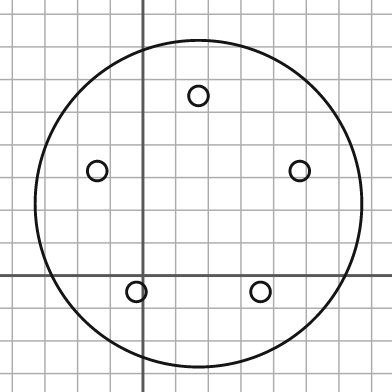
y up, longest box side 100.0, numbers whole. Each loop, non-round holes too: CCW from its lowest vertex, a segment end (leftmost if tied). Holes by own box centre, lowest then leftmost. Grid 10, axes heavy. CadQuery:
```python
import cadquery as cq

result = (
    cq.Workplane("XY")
    .moveTo(17.0, 22.0)
    .circle(50.0)
    .moveTo(-2.0, -5.0)
    .circle(3.0)
    .moveTo(36.0, -5.0)
    .circle(3.0)
    .moveTo(-14.0, 32.0)
    .circle(3.0)
    .moveTo(48.0, 32.0)
    .circle(3.0)
    .moveTo(17.0, 55.0)
    .circle(3.0)
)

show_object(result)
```